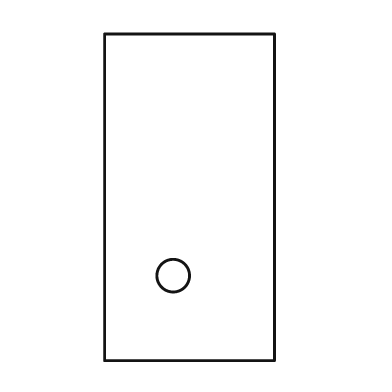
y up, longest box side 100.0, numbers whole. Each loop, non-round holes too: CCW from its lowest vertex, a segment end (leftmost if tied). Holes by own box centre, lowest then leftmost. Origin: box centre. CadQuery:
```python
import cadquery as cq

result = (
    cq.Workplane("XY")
    .moveTo(-26.0, -50.0)
    .lineTo(26.0, -50.0)
    .lineTo(26.0, 50.0)
    .lineTo(-26.0, 50.0)
    .close()
    .moveTo(-5.0, -24.0)
    .circle(5.0)
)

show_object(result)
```